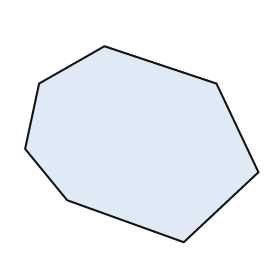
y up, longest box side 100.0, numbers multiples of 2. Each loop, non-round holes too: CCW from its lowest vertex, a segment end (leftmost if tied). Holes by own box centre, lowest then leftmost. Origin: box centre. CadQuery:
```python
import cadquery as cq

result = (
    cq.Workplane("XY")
    .moveTo(18.0, -42.0)
    .lineTo(50.0, -12.0)
    .lineTo(32.0, 26.0)
    .lineTo(-16.0, 42.0)
    .lineTo(-44.0, 26.0)
    .lineTo(-50.0, -2.0)
    .lineTo(-32.0, -24.0)
    .close()
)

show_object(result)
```